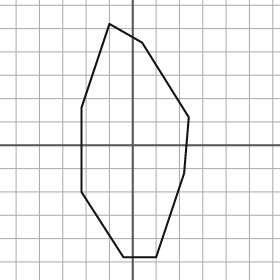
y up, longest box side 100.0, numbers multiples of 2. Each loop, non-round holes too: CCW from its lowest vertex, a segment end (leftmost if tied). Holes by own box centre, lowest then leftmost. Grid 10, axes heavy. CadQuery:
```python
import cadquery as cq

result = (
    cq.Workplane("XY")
    .moveTo(-4.0, -48.0)
    .lineTo(10.0, -48.0)
    .lineTo(22.0, -12.0)
    .lineTo(24.0, 12.0)
    .lineTo(4.0, 44.0)
    .lineTo(-10.0, 52.0)
    .lineTo(-22.0, 16.0)
    .lineTo(-22.0, -20.0)
    .close()
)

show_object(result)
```